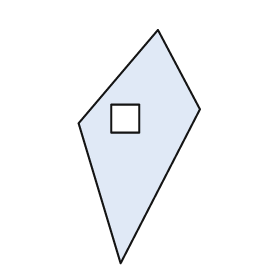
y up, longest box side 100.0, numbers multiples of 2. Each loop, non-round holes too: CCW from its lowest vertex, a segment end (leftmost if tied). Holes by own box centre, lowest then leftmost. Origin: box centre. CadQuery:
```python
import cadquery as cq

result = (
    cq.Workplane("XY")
    .moveTo(-8.0, -50.0)
    .lineTo(26.0, 16.0)
    .lineTo(8.0, 50.0)
    .lineTo(-26.0, 10.0)
    .close()
    .moveTo(-12.0, 6.0)
    .lineTo(0.0, 6.0)
    .lineTo(0.0, 18.0)
    .lineTo(-12.0, 18.0)
    .close()
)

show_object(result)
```